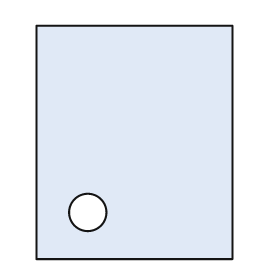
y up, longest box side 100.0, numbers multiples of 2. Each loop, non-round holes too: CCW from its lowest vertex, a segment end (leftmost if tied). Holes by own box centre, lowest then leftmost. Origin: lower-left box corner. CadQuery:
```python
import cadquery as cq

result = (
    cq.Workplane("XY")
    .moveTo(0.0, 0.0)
    .lineTo(84.0, 0.0)
    .lineTo(84.0, 100.0)
    .lineTo(0.0, 100.0)
    .close()
    .moveTo(22.0, 20.0)
    .circle(8.0)
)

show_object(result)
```